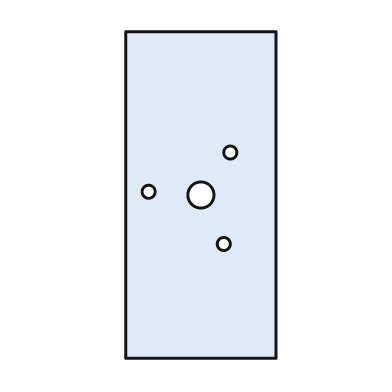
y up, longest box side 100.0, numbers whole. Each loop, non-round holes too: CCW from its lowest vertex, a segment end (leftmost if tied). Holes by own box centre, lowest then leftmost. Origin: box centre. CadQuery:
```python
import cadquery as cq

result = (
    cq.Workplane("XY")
    .moveTo(-23.0, -50.0)
    .lineTo(23.0, -50.0)
    .lineTo(23.0, 50.0)
    .lineTo(-23.0, 50.0)
    .close()
    .moveTo(7.0, -15.0)
    .circle(2.0)
    .moveTo(0.0, 0.0)
    .circle(4.0)
    .moveTo(-16.0, 1.0)
    .circle(2.0)
    .moveTo(9.0, 13.0)
    .circle(2.0)
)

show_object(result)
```